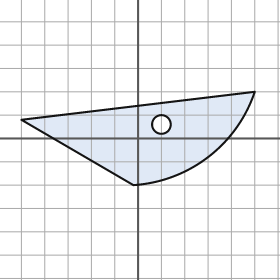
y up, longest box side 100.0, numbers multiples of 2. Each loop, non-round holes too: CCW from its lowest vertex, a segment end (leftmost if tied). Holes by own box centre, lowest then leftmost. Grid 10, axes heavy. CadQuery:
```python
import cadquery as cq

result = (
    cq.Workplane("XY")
    .moveTo(-2.0, -20.0)
    .threePointArc((30.0, -8.0), (50.0, 20.0))
    .lineTo(-50.0, 8.0)
    .close()
    .moveTo(10.0, 6.0)
    .circle(4.0)
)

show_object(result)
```